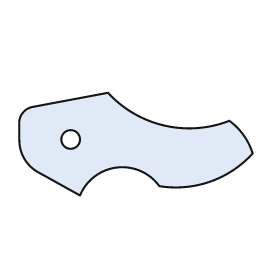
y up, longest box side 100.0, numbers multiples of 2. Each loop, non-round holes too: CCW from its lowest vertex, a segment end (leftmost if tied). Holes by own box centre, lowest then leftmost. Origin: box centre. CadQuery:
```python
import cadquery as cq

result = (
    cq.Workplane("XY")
    .moveTo(-24.0, -22.0)
    .threePointArc((-8.0, -10.0), (10.0, -18.0))
    .threePointArc((32.0, -16.0), (50.0, -4.0))
    .threePointArc((46.0, 4.0), (40.0, 10.0))
    .threePointArc((12.0, 8.0), (-12.0, 22.0))
    .lineTo(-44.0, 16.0)
    .threePointArc((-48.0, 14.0), (-50.0, 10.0))
    .lineTo(-50.0, 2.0)
    .threePointArc((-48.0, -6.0), (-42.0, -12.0))
    .close()
    .moveTo(-28.0, 2.0)
    .circle(4.0)
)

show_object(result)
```